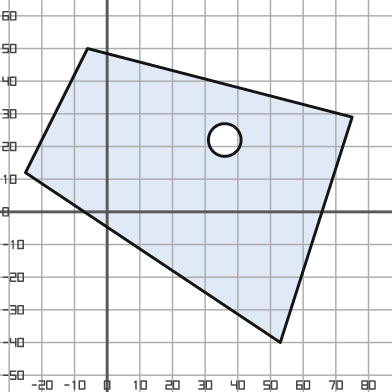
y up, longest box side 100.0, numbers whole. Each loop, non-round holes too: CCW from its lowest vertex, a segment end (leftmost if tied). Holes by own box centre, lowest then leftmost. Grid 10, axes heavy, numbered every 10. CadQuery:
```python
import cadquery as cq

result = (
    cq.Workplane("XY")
    .moveTo(53.0, -40.0)
    .lineTo(75.0, 29.0)
    .lineTo(-6.0, 50.0)
    .lineTo(-25.0, 12.0)
    .close()
    .moveTo(36.0, 22.0)
    .circle(5.0)
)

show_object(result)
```